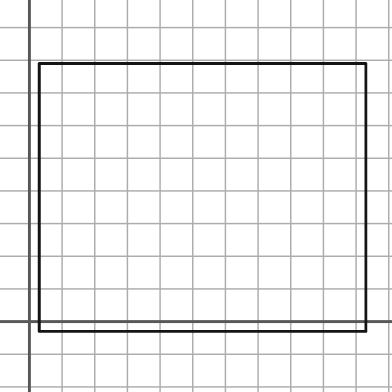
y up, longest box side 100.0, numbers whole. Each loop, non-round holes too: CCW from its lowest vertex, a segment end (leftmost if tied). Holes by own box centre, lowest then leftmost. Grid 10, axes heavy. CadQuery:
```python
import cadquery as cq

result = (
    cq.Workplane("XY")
    .moveTo(3.0, -3.0)
    .lineTo(103.0, -3.0)
    .lineTo(103.0, 79.0)
    .lineTo(3.0, 79.0)
    .close()
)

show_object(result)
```